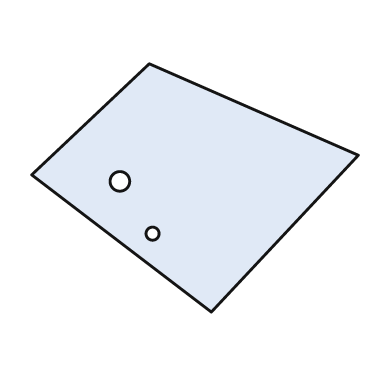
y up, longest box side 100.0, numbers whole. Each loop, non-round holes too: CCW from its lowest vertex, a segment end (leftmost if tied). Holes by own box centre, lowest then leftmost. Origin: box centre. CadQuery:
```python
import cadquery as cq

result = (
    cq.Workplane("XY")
    .moveTo(5.0, -38.0)
    .lineTo(50.0, 10.0)
    .lineTo(-14.0, 38.0)
    .lineTo(-50.0, 4.0)
    .close()
    .moveTo(-13.0, -14.0)
    .circle(2.0)
    .moveTo(-23.0, 2.0)
    .circle(3.0)
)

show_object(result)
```